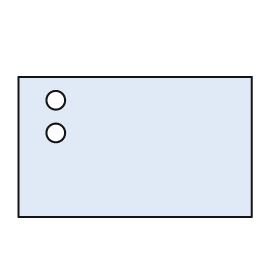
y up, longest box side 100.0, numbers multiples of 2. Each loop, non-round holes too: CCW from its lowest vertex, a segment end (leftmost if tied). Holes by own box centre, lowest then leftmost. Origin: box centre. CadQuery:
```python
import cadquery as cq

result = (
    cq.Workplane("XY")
    .moveTo(-50.0, -30.0)
    .lineTo(50.0, -30.0)
    .lineTo(50.0, 30.0)
    .lineTo(-50.0, 30.0)
    .close()
    .moveTo(-34.0, 6.0)
    .circle(4.0)
    .moveTo(-34.0, 20.0)
    .circle(4.0)
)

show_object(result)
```